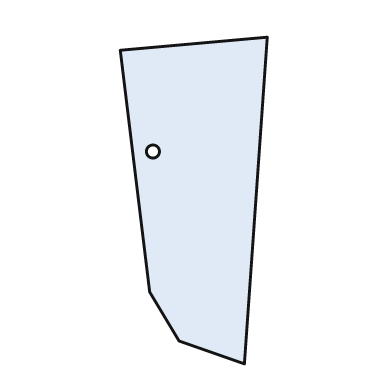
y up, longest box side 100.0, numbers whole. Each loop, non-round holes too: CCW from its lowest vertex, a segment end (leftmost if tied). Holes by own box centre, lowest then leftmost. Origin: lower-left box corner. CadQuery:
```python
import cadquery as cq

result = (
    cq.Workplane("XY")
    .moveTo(38.0, 0.0)
    .lineTo(45.0, 100.0)
    .lineTo(0.0, 96.0)
    .lineTo(9.0, 22.0)
    .lineTo(18.0, 7.0)
    .close()
    .moveTo(10.0, 65.0)
    .circle(2.0)
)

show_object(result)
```